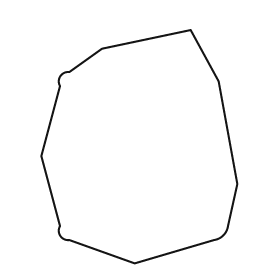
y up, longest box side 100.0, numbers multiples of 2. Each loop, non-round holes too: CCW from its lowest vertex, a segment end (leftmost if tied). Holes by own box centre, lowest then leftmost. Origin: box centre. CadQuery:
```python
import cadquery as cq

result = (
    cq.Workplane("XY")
    .moveTo(-2.0, -50.0)
    .lineTo(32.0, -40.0)
    .threePointArc((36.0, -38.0), (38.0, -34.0))
    .lineTo(42.0, -16.0)
    .lineTo(34.0, 28.0)
    .lineTo(22.0, 50.0)
    .lineTo(-16.0, 42.0)
    .lineTo(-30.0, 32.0)
    .threePointArc((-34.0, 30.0), (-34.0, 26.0))
    .lineTo(-42.0, -4.0)
    .lineTo(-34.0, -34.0)
    .threePointArc((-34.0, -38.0), (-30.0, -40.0))
    .close()
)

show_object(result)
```